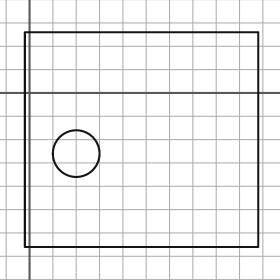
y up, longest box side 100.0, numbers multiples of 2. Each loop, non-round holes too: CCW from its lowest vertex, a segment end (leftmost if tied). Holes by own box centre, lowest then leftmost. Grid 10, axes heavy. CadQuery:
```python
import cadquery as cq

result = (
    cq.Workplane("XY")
    .moveTo(-2.0, -66.0)
    .lineTo(98.0, -66.0)
    .lineTo(98.0, 26.0)
    .lineTo(-2.0, 26.0)
    .close()
    .moveTo(20.0, -26.0)
    .circle(10.0)
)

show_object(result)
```